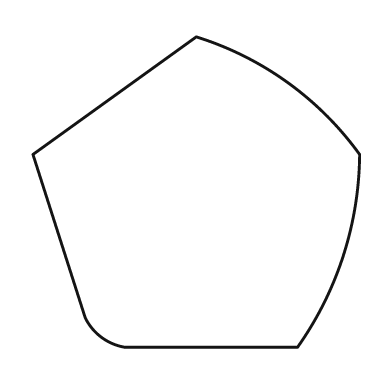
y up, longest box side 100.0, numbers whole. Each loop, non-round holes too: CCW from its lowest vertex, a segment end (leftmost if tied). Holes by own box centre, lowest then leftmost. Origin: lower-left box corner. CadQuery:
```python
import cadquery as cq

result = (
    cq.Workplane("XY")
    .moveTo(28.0, 0.0)
    .lineTo(81.0, 0.0)
    .threePointArc((95.0, 28.0), (100.0, 59.0))
    .threePointArc((78.0, 81.0), (50.0, 95.0))
    .lineTo(0.0, 59.0)
    .lineTo(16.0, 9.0)
    .threePointArc((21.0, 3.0), (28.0, 0.0))
    .close()
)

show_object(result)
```